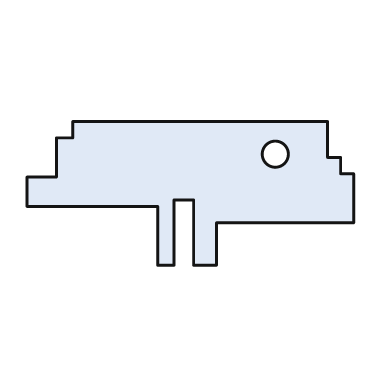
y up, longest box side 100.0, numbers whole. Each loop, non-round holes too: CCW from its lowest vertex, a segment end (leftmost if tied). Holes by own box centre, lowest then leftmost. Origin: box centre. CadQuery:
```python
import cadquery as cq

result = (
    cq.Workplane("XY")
    .moveTo(-10.0, -22.0)
    .lineTo(-5.0, -22.0)
    .lineTo(-5.0, -2.0)
    .lineTo(1.0, -2.0)
    .lineTo(1.0, -22.0)
    .lineTo(8.0, -22.0)
    .lineTo(8.0, -9.0)
    .lineTo(50.0, -9.0)
    .lineTo(50.0, 6.0)
    .lineTo(46.0, 6.0)
    .lineTo(46.0, 11.0)
    .lineTo(42.0, 11.0)
    .lineTo(42.0, 22.0)
    .lineTo(-36.0, 22.0)
    .lineTo(-36.0, 17.0)
    .lineTo(-41.0, 17.0)
    .lineTo(-41.0, 5.0)
    .lineTo(-50.0, 5.0)
    .lineTo(-50.0, -4.0)
    .lineTo(-10.0, -4.0)
    .close()
    .moveTo(26.0, 12.0)
    .circle(4.0)
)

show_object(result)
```